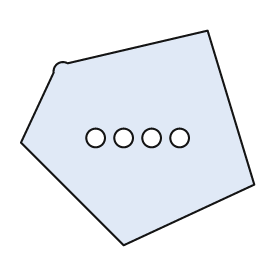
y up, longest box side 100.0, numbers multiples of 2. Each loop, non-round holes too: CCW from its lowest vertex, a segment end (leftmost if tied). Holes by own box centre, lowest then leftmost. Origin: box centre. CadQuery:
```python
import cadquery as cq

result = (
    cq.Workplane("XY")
    .moveTo(-6.0, -46.0)
    .lineTo(50.0, -20.0)
    .lineTo(30.0, 46.0)
    .lineTo(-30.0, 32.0)
    .threePointArc((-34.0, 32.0), (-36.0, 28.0))
    .lineTo(-50.0, -2.0)
    .close()
    .moveTo(-18.0, 0.0)
    .circle(4.0)
    .moveTo(-6.0, 0.0)
    .circle(4.0)
    .moveTo(6.0, 0.0)
    .circle(4.0)
    .moveTo(18.0, 0.0)
    .circle(4.0)
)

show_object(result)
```